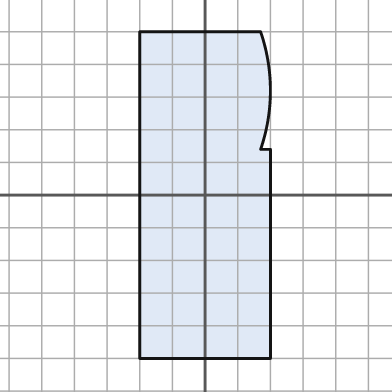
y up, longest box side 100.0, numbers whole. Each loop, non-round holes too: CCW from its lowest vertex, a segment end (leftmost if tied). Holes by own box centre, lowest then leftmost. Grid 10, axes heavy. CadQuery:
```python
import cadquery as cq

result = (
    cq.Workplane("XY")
    .moveTo(-20.0, -50.0)
    .lineTo(20.0, -50.0)
    .lineTo(20.0, 14.0)
    .lineTo(17.0, 14.0)
    .threePointArc((20.0, 32.0), (17.0, 50.0))
    .lineTo(-20.0, 50.0)
    .close()
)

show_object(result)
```